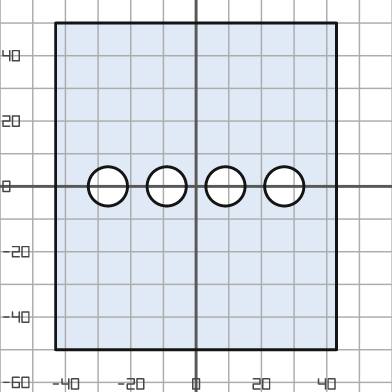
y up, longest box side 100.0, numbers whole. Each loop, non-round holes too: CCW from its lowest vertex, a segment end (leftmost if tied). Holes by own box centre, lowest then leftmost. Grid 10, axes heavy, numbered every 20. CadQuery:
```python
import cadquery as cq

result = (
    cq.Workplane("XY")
    .moveTo(-43.0, -50.0)
    .lineTo(43.0, -50.0)
    .lineTo(43.0, 50.0)
    .lineTo(-43.0, 50.0)
    .close()
    .moveTo(-27.0, 0.0)
    .circle(6.0)
    .moveTo(-9.0, 0.0)
    .circle(6.0)
    .moveTo(9.0, 0.0)
    .circle(6.0)
    .moveTo(27.0, 0.0)
    .circle(6.0)
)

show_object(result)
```